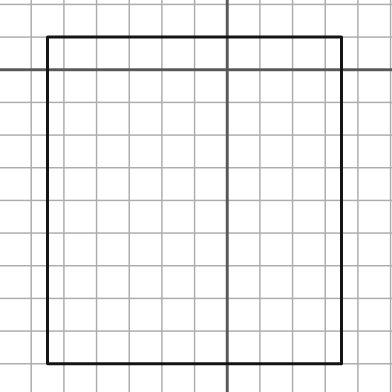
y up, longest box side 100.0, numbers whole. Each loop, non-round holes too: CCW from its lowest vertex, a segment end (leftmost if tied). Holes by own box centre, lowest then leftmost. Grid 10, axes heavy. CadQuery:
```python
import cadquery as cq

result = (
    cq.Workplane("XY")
    .moveTo(-55.0, -90.0)
    .lineTo(35.0, -90.0)
    .lineTo(35.0, 10.0)
    .lineTo(-55.0, 10.0)
    .close()
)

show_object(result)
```